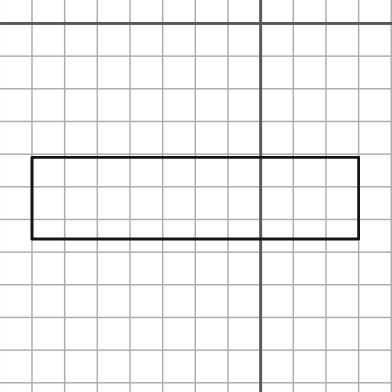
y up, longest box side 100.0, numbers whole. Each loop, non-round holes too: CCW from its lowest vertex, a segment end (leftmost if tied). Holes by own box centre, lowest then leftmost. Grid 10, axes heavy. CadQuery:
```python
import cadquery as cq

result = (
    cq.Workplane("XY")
    .moveTo(-70.0, -66.0)
    .lineTo(30.0, -66.0)
    .lineTo(30.0, -41.0)
    .lineTo(-70.0, -41.0)
    .close()
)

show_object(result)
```